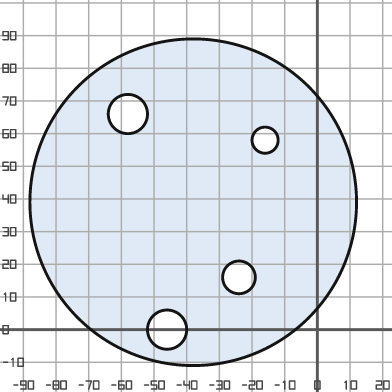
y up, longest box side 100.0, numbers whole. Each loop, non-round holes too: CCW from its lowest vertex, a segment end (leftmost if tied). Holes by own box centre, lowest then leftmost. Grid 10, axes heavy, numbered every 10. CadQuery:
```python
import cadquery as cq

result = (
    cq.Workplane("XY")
    .moveTo(-38.0, 39.0)
    .circle(50.0)
    .moveTo(-46.0, 0.0)
    .circle(6.0)
    .moveTo(-24.0, 16.0)
    .circle(5.0)
    .moveTo(-16.0, 58.0)
    .circle(4.0)
    .moveTo(-58.0, 66.0)
    .circle(6.0)
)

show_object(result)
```